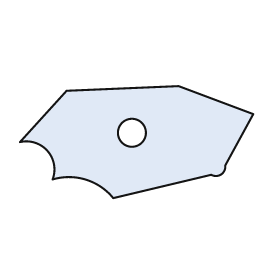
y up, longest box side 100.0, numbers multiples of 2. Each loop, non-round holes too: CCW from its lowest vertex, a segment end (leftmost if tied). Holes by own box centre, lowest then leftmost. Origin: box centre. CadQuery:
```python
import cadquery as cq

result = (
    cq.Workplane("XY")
    .moveTo(-10.0, -24.0)
    .lineTo(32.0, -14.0)
    .threePointArc((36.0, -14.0), (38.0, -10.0))
    .lineTo(50.0, 12.0)
    .lineTo(18.0, 24.0)
    .lineTo(-30.0, 22.0)
    .lineTo(-50.0, 0.0)
    .threePointArc((-38.0, -4.0), (-36.0, -16.0))
    .threePointArc((-22.0, -16.0), (-10.0, -24.0))
    .close()
    .moveTo(-2.0, 4.0)
    .circle(6.0)
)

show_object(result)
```